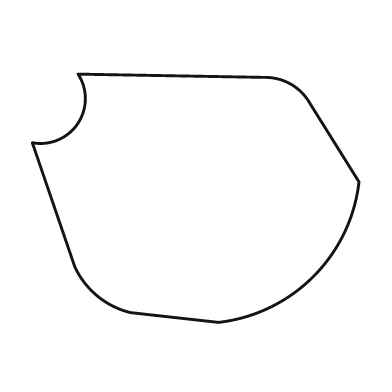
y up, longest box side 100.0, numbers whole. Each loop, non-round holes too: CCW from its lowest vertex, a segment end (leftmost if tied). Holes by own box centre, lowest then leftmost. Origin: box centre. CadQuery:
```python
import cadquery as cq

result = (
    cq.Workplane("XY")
    .moveTo(7.0, -38.0)
    .threePointArc((36.0, -24.0), (50.0, 5.0))
    .lineTo(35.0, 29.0)
    .threePointArc((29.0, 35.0), (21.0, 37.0))
    .lineTo(-36.0, 38.0)
    .threePointArc((-36.0, 23.0), (-50.0, 17.0))
    .lineTo(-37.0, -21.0)
    .threePointArc((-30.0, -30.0), (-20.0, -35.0))
    .close()
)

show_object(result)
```